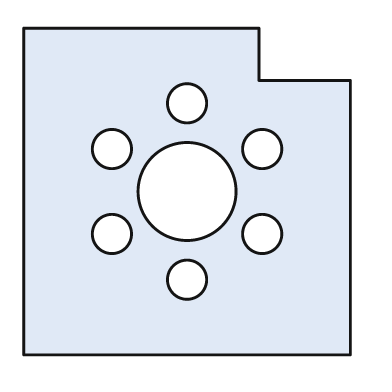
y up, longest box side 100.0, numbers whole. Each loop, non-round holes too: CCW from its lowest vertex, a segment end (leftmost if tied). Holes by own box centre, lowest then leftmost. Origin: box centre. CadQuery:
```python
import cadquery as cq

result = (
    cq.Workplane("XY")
    .moveTo(-50.0, -50.0)
    .lineTo(50.0, -50.0)
    .lineTo(50.0, 34.0)
    .lineTo(22.0, 34.0)
    .lineTo(22.0, 50.0)
    .lineTo(-50.0, 50.0)
    .close()
    .moveTo(0.0, -27.0)
    .circle(6.0)
    .moveTo(-23.0, -13.0)
    .circle(6.0)
    .moveTo(23.0, -13.0)
    .circle(6.0)
    .moveTo(0.0, 0.0)
    .circle(15.0)
    .moveTo(-23.0, 13.0)
    .circle(6.0)
    .moveTo(23.0, 13.0)
    .circle(6.0)
    .moveTo(0.0, 27.0)
    .circle(6.0)
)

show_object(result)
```